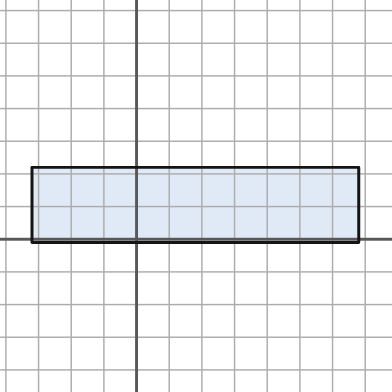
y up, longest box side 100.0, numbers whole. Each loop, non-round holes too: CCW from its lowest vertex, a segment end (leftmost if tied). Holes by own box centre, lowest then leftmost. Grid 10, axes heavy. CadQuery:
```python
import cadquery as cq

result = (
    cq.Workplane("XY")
    .moveTo(-32.0, -1.0)
    .lineTo(68.0, -1.0)
    .lineTo(68.0, 22.0)
    .lineTo(-32.0, 22.0)
    .close()
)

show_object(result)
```